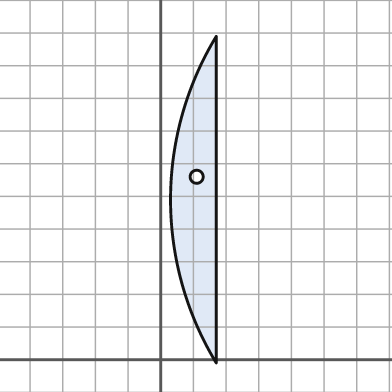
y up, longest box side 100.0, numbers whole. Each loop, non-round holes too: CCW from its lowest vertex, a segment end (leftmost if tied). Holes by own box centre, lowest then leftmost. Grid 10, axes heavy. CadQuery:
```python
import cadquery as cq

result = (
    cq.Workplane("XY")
    .moveTo(17.0, -1.0)
    .lineTo(17.0, 99.0)
    .threePointArc((3.0, 49.0), (17.0, -1.0))
    .close()
    .moveTo(11.0, 56.0)
    .circle(2.0)
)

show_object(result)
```